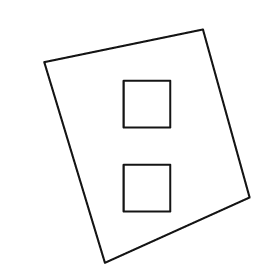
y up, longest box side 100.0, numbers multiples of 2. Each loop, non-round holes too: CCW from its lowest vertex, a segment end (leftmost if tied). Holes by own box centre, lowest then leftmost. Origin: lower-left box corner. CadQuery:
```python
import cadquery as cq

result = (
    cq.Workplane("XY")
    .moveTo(26.0, 0.0)
    .lineTo(88.0, 28.0)
    .lineTo(68.0, 100.0)
    .lineTo(0.0, 86.0)
    .close()
    .moveTo(34.0, 22.0)
    .lineTo(54.0, 22.0)
    .lineTo(54.0, 42.0)
    .lineTo(34.0, 42.0)
    .close()
    .moveTo(34.0, 58.0)
    .lineTo(54.0, 58.0)
    .lineTo(54.0, 78.0)
    .lineTo(34.0, 78.0)
    .close()
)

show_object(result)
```